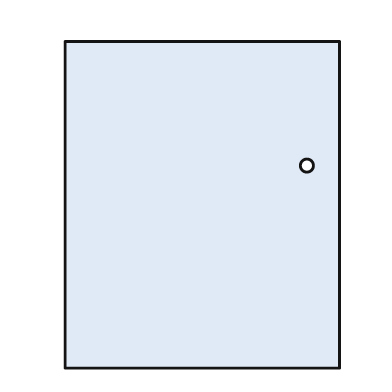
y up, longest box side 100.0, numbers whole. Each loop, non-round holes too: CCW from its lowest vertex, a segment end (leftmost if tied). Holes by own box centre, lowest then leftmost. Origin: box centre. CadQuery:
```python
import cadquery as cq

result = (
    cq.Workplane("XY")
    .moveTo(-42.0, -50.0)
    .lineTo(42.0, -50.0)
    .lineTo(42.0, 50.0)
    .lineTo(-42.0, 50.0)
    .close()
    .moveTo(32.0, 12.0)
    .circle(2.0)
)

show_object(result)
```